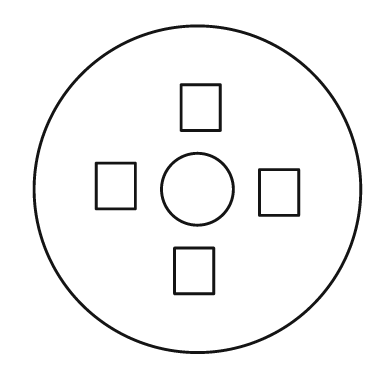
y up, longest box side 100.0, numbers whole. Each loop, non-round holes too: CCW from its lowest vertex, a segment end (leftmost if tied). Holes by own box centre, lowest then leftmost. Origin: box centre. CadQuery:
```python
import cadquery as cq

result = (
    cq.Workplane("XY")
    .moveTo(0.0, 0.0)
    .circle(50.0)
    .moveTo(-7.0, -32.0)
    .lineTo(5.0, -32.0)
    .lineTo(5.0, -18.0)
    .lineTo(-7.0, -18.0)
    .close()
    .moveTo(19.0, -8.0)
    .lineTo(31.0, -8.0)
    .lineTo(31.0, 6.0)
    .lineTo(19.0, 6.0)
    .close()
    .moveTo(0.0, 0.0)
    .circle(11.0)
    .moveTo(-31.0, -6.0)
    .lineTo(-19.0, -6.0)
    .lineTo(-19.0, 8.0)
    .lineTo(-31.0, 8.0)
    .close()
    .moveTo(-5.0, 18.0)
    .lineTo(7.0, 18.0)
    .lineTo(7.0, 32.0)
    .lineTo(-5.0, 32.0)
    .close()
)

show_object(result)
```